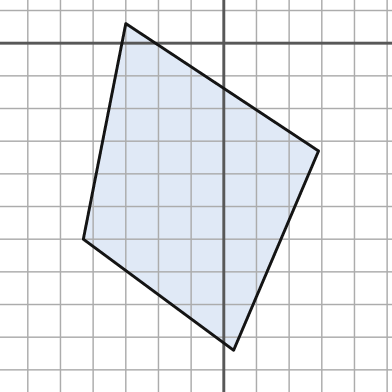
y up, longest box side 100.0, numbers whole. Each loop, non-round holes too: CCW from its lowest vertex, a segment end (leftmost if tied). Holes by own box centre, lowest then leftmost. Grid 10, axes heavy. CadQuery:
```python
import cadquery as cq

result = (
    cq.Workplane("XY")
    .moveTo(3.0, -94.0)
    .lineTo(29.0, -33.0)
    .lineTo(-30.0, 6.0)
    .lineTo(-43.0, -60.0)
    .close()
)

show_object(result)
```